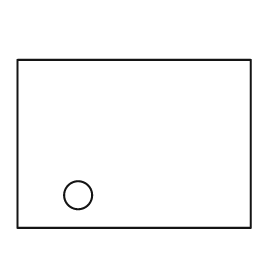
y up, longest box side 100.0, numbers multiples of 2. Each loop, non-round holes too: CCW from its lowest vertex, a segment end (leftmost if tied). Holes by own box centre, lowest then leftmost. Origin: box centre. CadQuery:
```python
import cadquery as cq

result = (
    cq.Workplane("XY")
    .moveTo(-50.0, -36.0)
    .lineTo(50.0, -36.0)
    .lineTo(50.0, 36.0)
    .lineTo(-50.0, 36.0)
    .close()
    .moveTo(-24.0, -22.0)
    .circle(6.0)
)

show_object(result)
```